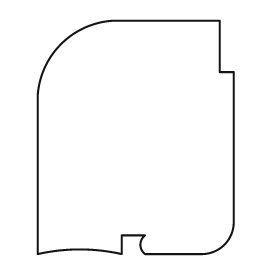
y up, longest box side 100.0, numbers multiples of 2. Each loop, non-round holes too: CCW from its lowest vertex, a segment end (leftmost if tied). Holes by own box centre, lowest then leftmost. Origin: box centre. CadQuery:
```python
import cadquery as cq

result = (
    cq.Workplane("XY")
    .moveTo(-42.0, -50.0)
    .threePointArc((-24.0, -48.0), (-6.0, -50.0))
    .lineTo(-6.0, -42.0)
    .lineTo(4.0, -42.0)
    .threePointArc((2.0, -46.0), (4.0, -50.0))
    .lineTo(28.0, -50.0)
    .threePointArc((38.0, -46.0), (42.0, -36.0))
    .lineTo(42.0, 28.0)
    .lineTo(36.0, 28.0)
    .lineTo(36.0, 50.0)
    .lineTo(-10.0, 50.0)
    .threePointArc((-32.0, 40.0), (-42.0, 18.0))
    .close()
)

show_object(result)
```